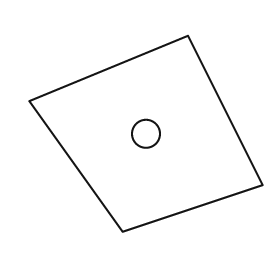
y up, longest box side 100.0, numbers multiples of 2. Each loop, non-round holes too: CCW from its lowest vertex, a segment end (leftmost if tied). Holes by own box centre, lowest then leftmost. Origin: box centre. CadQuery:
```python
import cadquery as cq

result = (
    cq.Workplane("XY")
    .moveTo(-10.0, -42.0)
    .lineTo(50.0, -22.0)
    .lineTo(18.0, 42.0)
    .lineTo(-50.0, 14.0)
    .close()
    .moveTo(0.0, 0.0)
    .circle(6.0)
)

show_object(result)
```